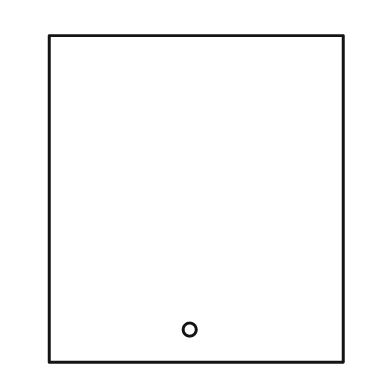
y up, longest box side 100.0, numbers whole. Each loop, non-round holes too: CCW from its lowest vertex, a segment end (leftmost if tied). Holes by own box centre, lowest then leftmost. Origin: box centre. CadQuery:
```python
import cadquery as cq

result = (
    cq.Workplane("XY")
    .moveTo(-45.0, -50.0)
    .lineTo(45.0, -50.0)
    .lineTo(45.0, 50.0)
    .lineTo(-45.0, 50.0)
    .close()
    .moveTo(-2.0, -40.0)
    .circle(2.0)
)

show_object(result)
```